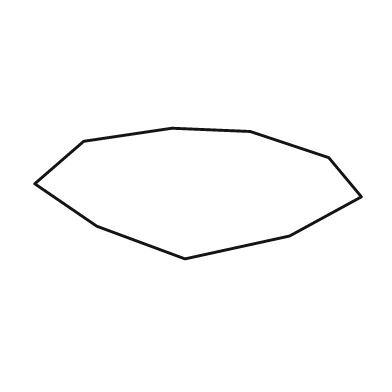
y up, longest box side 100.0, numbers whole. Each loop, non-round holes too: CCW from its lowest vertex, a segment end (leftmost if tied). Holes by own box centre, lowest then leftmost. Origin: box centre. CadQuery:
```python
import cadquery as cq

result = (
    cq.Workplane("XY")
    .moveTo(-4.0, -20.0)
    .lineTo(28.0, -13.0)
    .lineTo(50.0, -1.0)
    .lineTo(40.0, 11.0)
    .lineTo(16.0, 19.0)
    .lineTo(-8.0, 20.0)
    .lineTo(-35.0, 16.0)
    .lineTo(-50.0, 3.0)
    .lineTo(-31.0, -10.0)
    .close()
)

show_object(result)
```